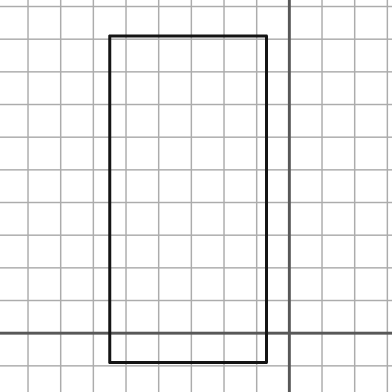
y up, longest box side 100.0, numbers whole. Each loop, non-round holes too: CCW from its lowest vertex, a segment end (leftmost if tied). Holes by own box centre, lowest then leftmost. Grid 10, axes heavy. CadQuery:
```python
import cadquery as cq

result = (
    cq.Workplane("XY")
    .moveTo(-55.0, -9.0)
    .lineTo(-7.0, -9.0)
    .lineTo(-7.0, 91.0)
    .lineTo(-55.0, 91.0)
    .close()
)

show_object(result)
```